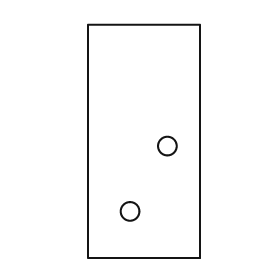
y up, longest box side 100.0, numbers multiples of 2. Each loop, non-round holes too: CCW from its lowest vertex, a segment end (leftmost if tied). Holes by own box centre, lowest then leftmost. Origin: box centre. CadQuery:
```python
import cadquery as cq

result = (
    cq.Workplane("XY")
    .moveTo(-24.0, -50.0)
    .lineTo(24.0, -50.0)
    .lineTo(24.0, 50.0)
    .lineTo(-24.0, 50.0)
    .close()
    .moveTo(-6.0, -30.0)
    .circle(4.0)
    .moveTo(10.0, -2.0)
    .circle(4.0)
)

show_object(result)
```